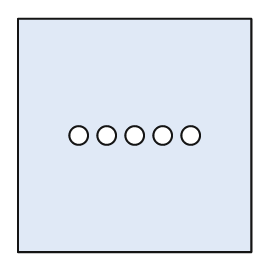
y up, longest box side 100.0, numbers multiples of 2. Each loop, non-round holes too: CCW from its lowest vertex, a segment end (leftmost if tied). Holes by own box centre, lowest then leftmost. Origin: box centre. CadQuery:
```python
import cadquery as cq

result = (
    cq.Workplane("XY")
    .moveTo(-50.0, -50.0)
    .lineTo(50.0, -50.0)
    .lineTo(50.0, 50.0)
    .lineTo(-50.0, 50.0)
    .close()
    .moveTo(-24.0, 0.0)
    .circle(4.0)
    .moveTo(-12.0, 0.0)
    .circle(4.0)
    .moveTo(0.0, 0.0)
    .circle(4.0)
    .moveTo(12.0, 0.0)
    .circle(4.0)
    .moveTo(24.0, 0.0)
    .circle(4.0)
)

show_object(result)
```